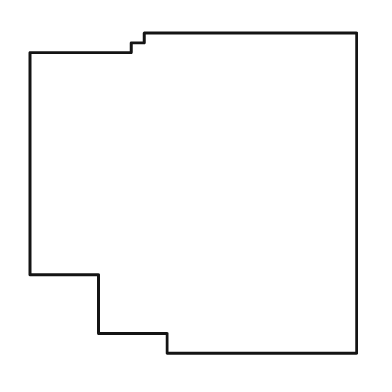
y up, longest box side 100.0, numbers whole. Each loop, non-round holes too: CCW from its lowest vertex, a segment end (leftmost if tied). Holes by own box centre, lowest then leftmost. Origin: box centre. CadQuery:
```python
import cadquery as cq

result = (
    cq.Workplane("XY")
    .moveTo(-8.0, -49.0)
    .lineTo(50.0, -49.0)
    .lineTo(50.0, 49.0)
    .lineTo(-15.0, 49.0)
    .lineTo(-15.0, 46.0)
    .lineTo(-19.0, 46.0)
    .lineTo(-19.0, 43.0)
    .lineTo(-50.0, 43.0)
    .lineTo(-50.0, -25.0)
    .lineTo(-29.0, -25.0)
    .lineTo(-29.0, -43.0)
    .lineTo(-8.0, -43.0)
    .close()
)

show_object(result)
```